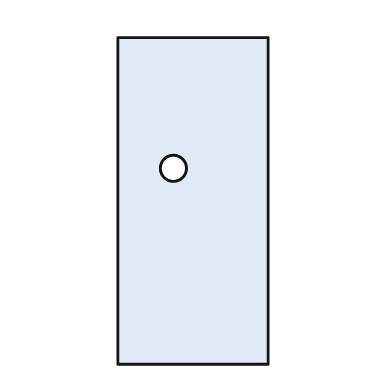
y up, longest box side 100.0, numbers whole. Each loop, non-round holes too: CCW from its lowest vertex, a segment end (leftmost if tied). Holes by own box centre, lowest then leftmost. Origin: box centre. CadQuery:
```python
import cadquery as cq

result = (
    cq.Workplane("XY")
    .moveTo(-23.0, -50.0)
    .lineTo(23.0, -50.0)
    .lineTo(23.0, 50.0)
    .lineTo(-23.0, 50.0)
    .close()
    .moveTo(-6.0, 10.0)
    .circle(4.0)
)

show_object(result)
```